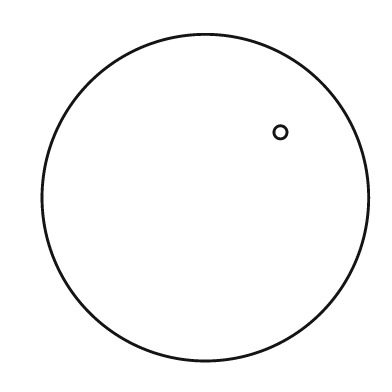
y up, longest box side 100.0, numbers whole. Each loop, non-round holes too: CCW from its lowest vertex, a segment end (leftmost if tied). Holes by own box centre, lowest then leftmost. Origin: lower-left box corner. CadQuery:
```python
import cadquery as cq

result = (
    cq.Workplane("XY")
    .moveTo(50.0, 50.0)
    .circle(50.0)
    .moveTo(73.0, 70.0)
    .circle(2.0)
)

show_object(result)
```